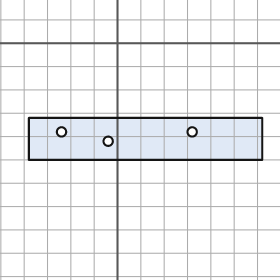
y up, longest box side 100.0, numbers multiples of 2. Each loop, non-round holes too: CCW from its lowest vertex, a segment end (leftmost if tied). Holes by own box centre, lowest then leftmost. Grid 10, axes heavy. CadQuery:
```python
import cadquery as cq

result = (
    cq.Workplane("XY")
    .moveTo(-38.0, -50.0)
    .lineTo(62.0, -50.0)
    .lineTo(62.0, -32.0)
    .lineTo(-38.0, -32.0)
    .close()
    .moveTo(-4.0, -42.0)
    .circle(2.0)
    .moveTo(-24.0, -38.0)
    .circle(2.0)
    .moveTo(32.0, -38.0)
    .circle(2.0)
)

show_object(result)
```